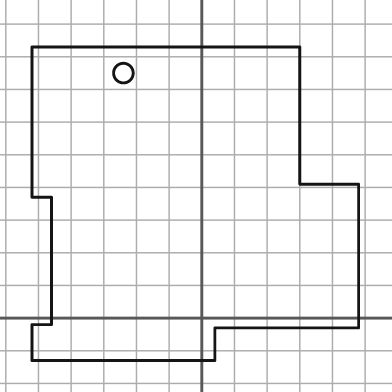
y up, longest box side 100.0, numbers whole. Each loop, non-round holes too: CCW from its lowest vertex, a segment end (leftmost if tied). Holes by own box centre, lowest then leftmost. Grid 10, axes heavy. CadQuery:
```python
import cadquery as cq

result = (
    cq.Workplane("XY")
    .moveTo(-52.0, -13.0)
    .lineTo(4.0, -13.0)
    .lineTo(4.0, -3.0)
    .lineTo(48.0, -3.0)
    .lineTo(48.0, 41.0)
    .lineTo(30.0, 41.0)
    .lineTo(30.0, 83.0)
    .lineTo(-52.0, 83.0)
    .lineTo(-52.0, 37.0)
    .lineTo(-46.0, 37.0)
    .lineTo(-46.0, -2.0)
    .lineTo(-52.0, -2.0)
    .close()
    .moveTo(-24.0, 75.0)
    .circle(3.0)
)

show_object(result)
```